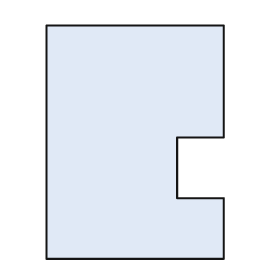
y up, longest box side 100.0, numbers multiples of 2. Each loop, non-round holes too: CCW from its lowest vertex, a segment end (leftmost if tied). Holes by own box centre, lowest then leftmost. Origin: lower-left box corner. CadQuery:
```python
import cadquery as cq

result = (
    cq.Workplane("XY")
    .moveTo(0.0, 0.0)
    .lineTo(76.0, 0.0)
    .lineTo(76.0, 26.0)
    .lineTo(56.0, 26.0)
    .lineTo(56.0, 52.0)
    .lineTo(76.0, 52.0)
    .lineTo(76.0, 100.0)
    .lineTo(0.0, 100.0)
    .close()
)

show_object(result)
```